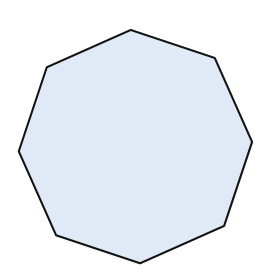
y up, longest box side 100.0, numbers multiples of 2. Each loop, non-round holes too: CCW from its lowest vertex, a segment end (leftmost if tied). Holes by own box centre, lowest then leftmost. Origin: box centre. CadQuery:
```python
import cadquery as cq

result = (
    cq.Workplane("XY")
    .moveTo(2.0, -50.0)
    .lineTo(38.0, -34.0)
    .lineTo(50.0, 2.0)
    .lineTo(34.0, 38.0)
    .lineTo(-2.0, 50.0)
    .lineTo(-38.0, 34.0)
    .lineTo(-50.0, -2.0)
    .lineTo(-34.0, -38.0)
    .close()
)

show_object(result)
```